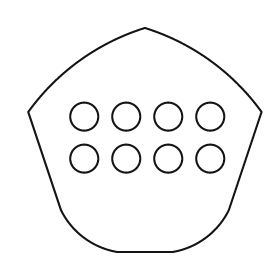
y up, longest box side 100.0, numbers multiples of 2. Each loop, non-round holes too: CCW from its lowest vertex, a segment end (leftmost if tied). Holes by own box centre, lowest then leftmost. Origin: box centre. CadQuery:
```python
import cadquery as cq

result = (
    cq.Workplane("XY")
    .moveTo(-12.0, -48.0)
    .lineTo(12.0, -48.0)
    .threePointArc((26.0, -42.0), (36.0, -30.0))
    .lineTo(50.0, 12.0)
    .threePointArc((28.0, 34.0), (0.0, 48.0))
    .threePointArc((-28.0, 34.0), (-50.0, 12.0))
    .lineTo(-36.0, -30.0)
    .threePointArc((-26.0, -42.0), (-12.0, -48.0))
    .close()
    .moveTo(-26.0, -8.0)
    .circle(6.0)
    .moveTo(-8.0, -8.0)
    .circle(6.0)
    .moveTo(10.0, -8.0)
    .circle(6.0)
    .moveTo(28.0, -8.0)
    .circle(6.0)
    .moveTo(-26.0, 10.0)
    .circle(6.0)
    .moveTo(-8.0, 10.0)
    .circle(6.0)
    .moveTo(10.0, 10.0)
    .circle(6.0)
    .moveTo(28.0, 10.0)
    .circle(6.0)
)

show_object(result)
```